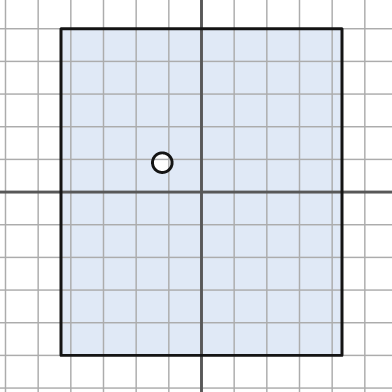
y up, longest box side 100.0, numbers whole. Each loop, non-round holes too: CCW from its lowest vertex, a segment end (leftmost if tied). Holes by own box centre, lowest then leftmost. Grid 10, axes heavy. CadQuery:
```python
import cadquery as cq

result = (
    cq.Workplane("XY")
    .moveTo(-43.0, -50.0)
    .lineTo(43.0, -50.0)
    .lineTo(43.0, 50.0)
    .lineTo(-43.0, 50.0)
    .close()
    .moveTo(-12.0, 9.0)
    .circle(3.0)
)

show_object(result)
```